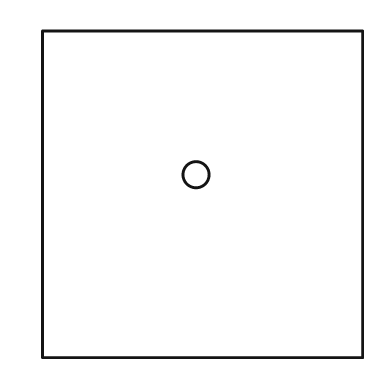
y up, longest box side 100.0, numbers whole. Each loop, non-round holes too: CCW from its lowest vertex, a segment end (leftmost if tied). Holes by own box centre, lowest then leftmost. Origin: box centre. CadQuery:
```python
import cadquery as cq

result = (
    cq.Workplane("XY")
    .moveTo(-49.0, -50.0)
    .lineTo(49.0, -50.0)
    .lineTo(49.0, 50.0)
    .lineTo(-49.0, 50.0)
    .close()
    .moveTo(-2.0, 6.0)
    .circle(4.0)
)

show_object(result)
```